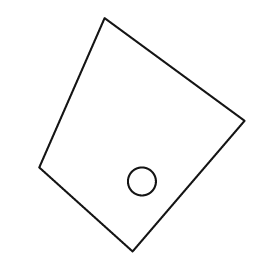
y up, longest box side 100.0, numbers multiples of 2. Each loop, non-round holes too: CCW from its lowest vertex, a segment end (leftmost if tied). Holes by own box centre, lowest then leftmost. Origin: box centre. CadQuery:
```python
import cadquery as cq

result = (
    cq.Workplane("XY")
    .moveTo(-4.0, -50.0)
    .lineTo(44.0, 6.0)
    .lineTo(-16.0, 50.0)
    .lineTo(-44.0, -14.0)
    .close()
    .moveTo(0.0, -20.0)
    .circle(6.0)
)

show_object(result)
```